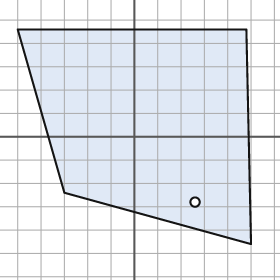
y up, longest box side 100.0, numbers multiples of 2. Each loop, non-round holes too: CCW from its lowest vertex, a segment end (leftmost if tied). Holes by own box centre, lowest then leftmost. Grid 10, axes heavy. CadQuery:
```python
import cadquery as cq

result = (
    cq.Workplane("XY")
    .moveTo(50.0, -46.0)
    .lineTo(48.0, 46.0)
    .lineTo(-50.0, 46.0)
    .lineTo(-30.0, -24.0)
    .close()
    .moveTo(26.0, -28.0)
    .circle(2.0)
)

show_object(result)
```